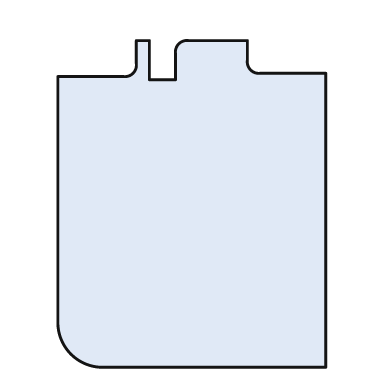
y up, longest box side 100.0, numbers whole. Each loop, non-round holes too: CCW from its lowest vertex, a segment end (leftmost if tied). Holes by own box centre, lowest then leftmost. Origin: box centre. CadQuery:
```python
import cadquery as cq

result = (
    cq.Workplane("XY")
    .moveTo(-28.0, -50.0)
    .lineTo(41.0, -50.0)
    .lineTo(41.0, 40.0)
    .lineTo(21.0, 40.0)
    .threePointArc((18.0, 41.0), (17.0, 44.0))
    .lineTo(17.0, 50.0)
    .lineTo(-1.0, 50.0)
    .threePointArc((-4.0, 49.0), (-5.0, 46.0))
    .lineTo(-5.0, 38.0)
    .lineTo(-13.0, 38.0)
    .lineTo(-13.0, 50.0)
    .lineTo(-17.0, 50.0)
    .lineTo(-17.0, 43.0)
    .threePointArc((-18.0, 40.0), (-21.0, 39.0))
    .lineTo(-41.0, 39.0)
    .lineTo(-41.0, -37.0)
    .threePointArc((-37.0, -46.0), (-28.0, -50.0))
    .close()
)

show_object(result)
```